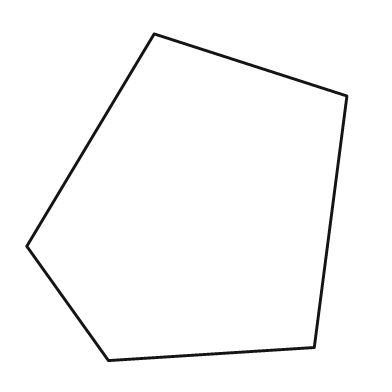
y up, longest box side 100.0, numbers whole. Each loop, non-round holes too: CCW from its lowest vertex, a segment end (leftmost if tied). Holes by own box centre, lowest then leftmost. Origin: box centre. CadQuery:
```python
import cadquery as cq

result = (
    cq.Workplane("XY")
    .moveTo(-24.0, -50.0)
    .lineTo(39.0, -46.0)
    .lineTo(49.0, 31.0)
    .lineTo(-10.0, 50.0)
    .lineTo(-49.0, -15.0)
    .close()
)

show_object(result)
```